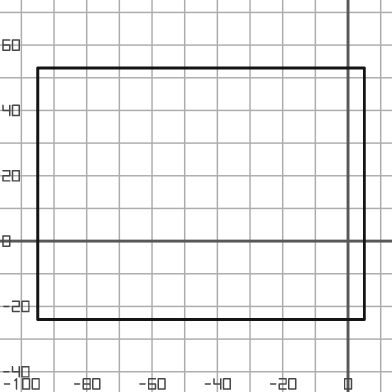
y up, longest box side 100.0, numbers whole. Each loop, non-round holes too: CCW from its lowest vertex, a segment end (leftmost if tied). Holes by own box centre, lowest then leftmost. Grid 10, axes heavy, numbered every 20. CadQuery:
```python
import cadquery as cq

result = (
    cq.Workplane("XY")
    .moveTo(-95.0, -24.0)
    .lineTo(5.0, -24.0)
    .lineTo(5.0, 53.0)
    .lineTo(-95.0, 53.0)
    .close()
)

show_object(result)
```